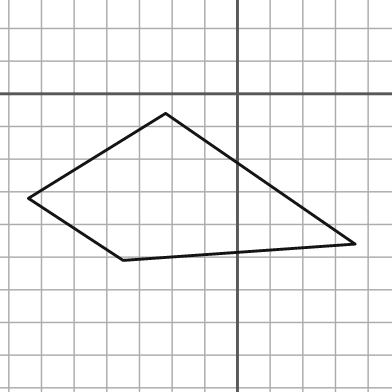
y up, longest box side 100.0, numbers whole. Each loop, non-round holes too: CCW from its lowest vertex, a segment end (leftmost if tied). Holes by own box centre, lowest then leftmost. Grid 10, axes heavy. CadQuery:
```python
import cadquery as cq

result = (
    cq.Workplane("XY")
    .moveTo(-35.0, -51.0)
    .lineTo(36.0, -46.0)
    .lineTo(-22.0, -6.0)
    .lineTo(-64.0, -32.0)
    .close()
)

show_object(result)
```